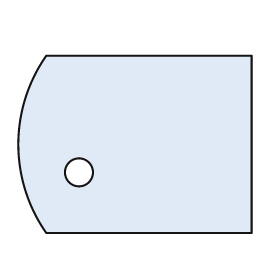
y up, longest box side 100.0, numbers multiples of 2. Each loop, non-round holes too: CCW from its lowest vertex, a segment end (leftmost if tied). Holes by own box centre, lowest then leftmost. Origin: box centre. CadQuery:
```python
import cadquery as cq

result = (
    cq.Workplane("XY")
    .moveTo(-38.0, -38.0)
    .lineTo(50.0, -38.0)
    .lineTo(50.0, 38.0)
    .lineTo(-38.0, 38.0)
    .threePointArc((-50.0, 0.0), (-38.0, -38.0))
    .close()
    .moveTo(-24.0, -12.0)
    .circle(6.0)
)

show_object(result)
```